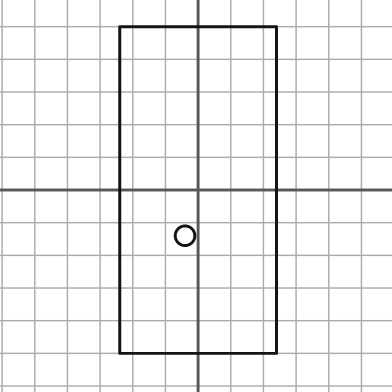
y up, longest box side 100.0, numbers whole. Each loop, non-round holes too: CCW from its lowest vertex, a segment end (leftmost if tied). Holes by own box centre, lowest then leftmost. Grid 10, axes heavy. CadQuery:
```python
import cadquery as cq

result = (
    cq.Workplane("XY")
    .moveTo(-24.0, -50.0)
    .lineTo(24.0, -50.0)
    .lineTo(24.0, 50.0)
    .lineTo(-24.0, 50.0)
    .close()
    .moveTo(-4.0, -14.0)
    .circle(3.0)
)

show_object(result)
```